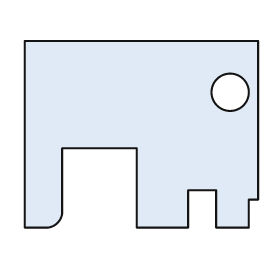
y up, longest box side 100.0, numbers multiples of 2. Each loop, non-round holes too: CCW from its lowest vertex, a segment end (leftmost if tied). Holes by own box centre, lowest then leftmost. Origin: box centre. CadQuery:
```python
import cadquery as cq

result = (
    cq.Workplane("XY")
    .moveTo(-50.0, -40.0)
    .lineTo(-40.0, -40.0)
    .threePointArc((-36.0, -38.0), (-34.0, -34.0))
    .lineTo(-34.0, -6.0)
    .lineTo(-2.0, -6.0)
    .lineTo(-2.0, -40.0)
    .lineTo(20.0, -40.0)
    .lineTo(20.0, -24.0)
    .lineTo(32.0, -24.0)
    .lineTo(32.0, -40.0)
    .lineTo(46.0, -40.0)
    .lineTo(46.0, -28.0)
    .lineTo(50.0, -28.0)
    .lineTo(50.0, 40.0)
    .lineTo(-50.0, 40.0)
    .close()
    .moveTo(38.0, 18.0)
    .circle(8.0)
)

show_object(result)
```